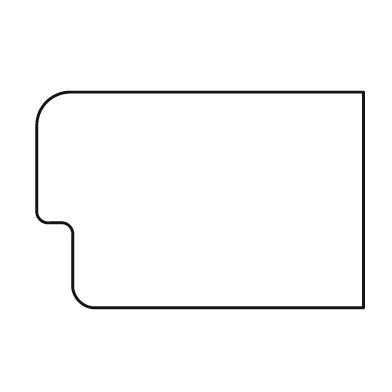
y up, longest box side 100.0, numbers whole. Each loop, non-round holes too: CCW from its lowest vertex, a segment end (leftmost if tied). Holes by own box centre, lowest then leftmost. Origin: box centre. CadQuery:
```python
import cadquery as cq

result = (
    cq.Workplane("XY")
    .moveTo(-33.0, -33.0)
    .lineTo(50.0, -33.0)
    .lineTo(50.0, 33.0)
    .lineTo(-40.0, 33.0)
    .threePointArc((-47.0, 30.0), (-50.0, 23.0))
    .lineTo(-50.0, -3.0)
    .threePointArc((-49.0, -6.0), (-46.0, -7.0))
    .lineTo(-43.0, -7.0)
    .threePointArc((-40.0, -8.0), (-39.0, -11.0))
    .lineTo(-39.0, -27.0)
    .threePointArc((-37.0, -31.0), (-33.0, -33.0))
    .close()
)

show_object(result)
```